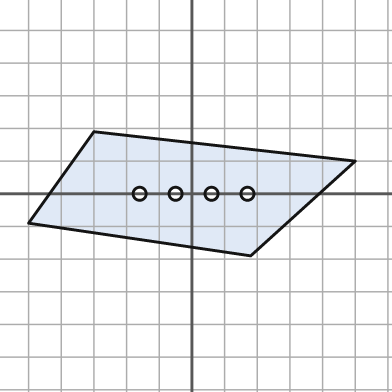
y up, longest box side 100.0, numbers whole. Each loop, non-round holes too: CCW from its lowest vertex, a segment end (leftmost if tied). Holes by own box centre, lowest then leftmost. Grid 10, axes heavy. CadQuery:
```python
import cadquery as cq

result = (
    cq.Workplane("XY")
    .moveTo(18.0, -19.0)
    .lineTo(50.0, 10.0)
    .lineTo(-30.0, 19.0)
    .lineTo(-50.0, -9.0)
    .close()
    .moveTo(-16.0, 0.0)
    .circle(2.0)
    .moveTo(-5.0, 0.0)
    .circle(2.0)
    .moveTo(6.0, 0.0)
    .circle(2.0)
    .moveTo(17.0, 0.0)
    .circle(2.0)
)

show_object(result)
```